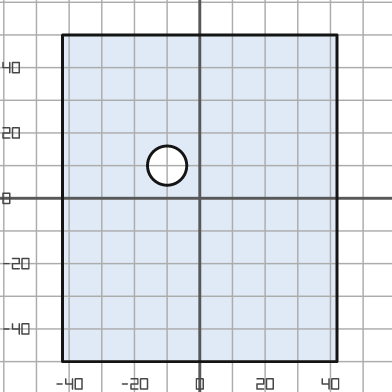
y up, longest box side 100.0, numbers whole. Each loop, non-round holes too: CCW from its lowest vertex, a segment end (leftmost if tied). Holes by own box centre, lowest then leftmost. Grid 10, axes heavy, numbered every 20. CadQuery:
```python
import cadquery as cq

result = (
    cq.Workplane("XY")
    .moveTo(-42.0, -50.0)
    .lineTo(42.0, -50.0)
    .lineTo(42.0, 50.0)
    .lineTo(-42.0, 50.0)
    .close()
    .moveTo(-10.0, 10.0)
    .circle(6.0)
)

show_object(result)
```